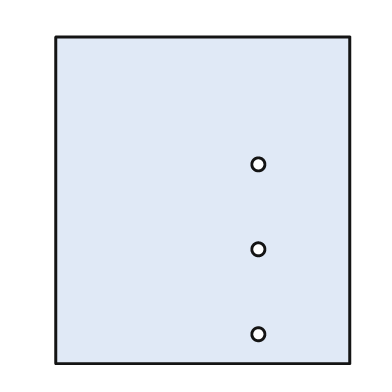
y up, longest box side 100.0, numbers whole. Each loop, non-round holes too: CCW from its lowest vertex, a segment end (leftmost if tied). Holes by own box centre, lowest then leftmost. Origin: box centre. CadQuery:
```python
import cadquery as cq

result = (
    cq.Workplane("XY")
    .moveTo(-45.0, -50.0)
    .lineTo(45.0, -50.0)
    .lineTo(45.0, 50.0)
    .lineTo(-45.0, 50.0)
    .close()
    .moveTo(17.0, -41.0)
    .circle(2.0)
    .moveTo(17.0, -15.0)
    .circle(2.0)
    .moveTo(17.0, 11.0)
    .circle(2.0)
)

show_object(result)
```